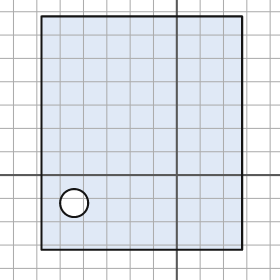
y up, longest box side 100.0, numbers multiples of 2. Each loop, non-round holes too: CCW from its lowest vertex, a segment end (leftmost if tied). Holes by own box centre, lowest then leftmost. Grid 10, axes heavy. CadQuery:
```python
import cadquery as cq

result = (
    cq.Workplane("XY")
    .moveTo(-58.0, -32.0)
    .lineTo(28.0, -32.0)
    .lineTo(28.0, 68.0)
    .lineTo(-58.0, 68.0)
    .close()
    .moveTo(-44.0, -12.0)
    .circle(6.0)
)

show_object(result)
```